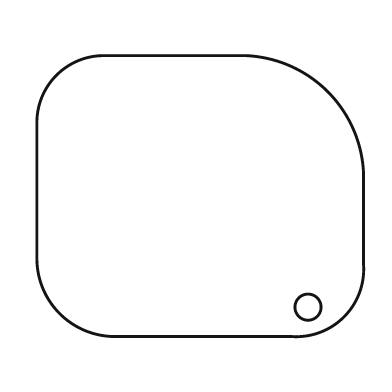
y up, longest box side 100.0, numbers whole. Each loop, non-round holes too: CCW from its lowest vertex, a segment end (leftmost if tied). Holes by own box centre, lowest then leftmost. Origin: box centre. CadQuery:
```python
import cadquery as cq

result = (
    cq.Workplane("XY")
    .moveTo(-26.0, -43.0)
    .lineTo(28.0, -43.0)
    .threePointArc((44.0, -37.0), (50.0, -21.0))
    .lineTo(50.0, 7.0)
    .threePointArc((39.0, 32.0), (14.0, 43.0))
    .lineTo(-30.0, 43.0)
    .threePointArc((-44.0, 37.0), (-50.0, 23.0))
    .lineTo(-50.0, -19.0)
    .threePointArc((-43.0, -36.0), (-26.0, -43.0))
    .close()
    .moveTo(33.0, -34.0)
    .circle(4.0)
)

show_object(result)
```